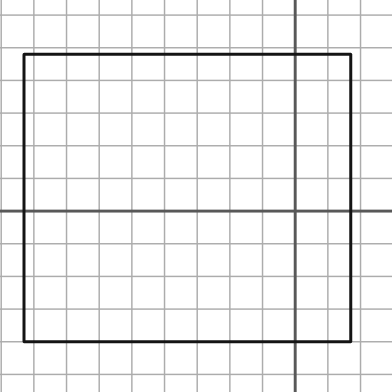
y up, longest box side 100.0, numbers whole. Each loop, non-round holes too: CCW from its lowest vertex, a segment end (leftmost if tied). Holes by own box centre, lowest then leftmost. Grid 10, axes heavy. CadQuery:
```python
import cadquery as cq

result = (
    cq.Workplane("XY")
    .moveTo(-83.0, -40.0)
    .lineTo(17.0, -40.0)
    .lineTo(17.0, 48.0)
    .lineTo(-83.0, 48.0)
    .close()
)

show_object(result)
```